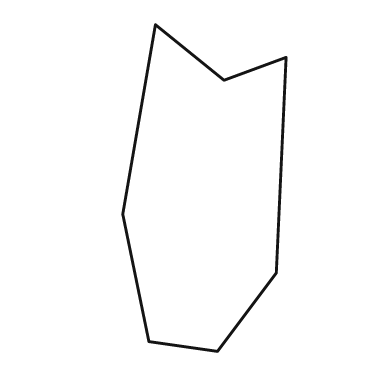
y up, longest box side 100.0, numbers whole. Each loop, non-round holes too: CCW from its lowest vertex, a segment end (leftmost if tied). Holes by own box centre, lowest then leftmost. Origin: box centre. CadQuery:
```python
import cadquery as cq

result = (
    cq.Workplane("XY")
    .moveTo(4.0, -50.0)
    .lineTo(22.0, -26.0)
    .lineTo(25.0, 40.0)
    .lineTo(6.0, 33.0)
    .lineTo(-15.0, 50.0)
    .lineTo(-25.0, -8.0)
    .lineTo(-17.0, -47.0)
    .close()
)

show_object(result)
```